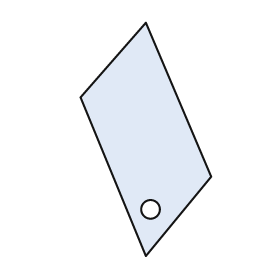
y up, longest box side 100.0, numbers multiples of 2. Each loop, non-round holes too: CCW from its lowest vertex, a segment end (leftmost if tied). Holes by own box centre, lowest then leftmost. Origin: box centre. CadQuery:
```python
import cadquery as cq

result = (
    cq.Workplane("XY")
    .moveTo(0.0, -50.0)
    .lineTo(28.0, -16.0)
    .lineTo(0.0, 50.0)
    .lineTo(-28.0, 18.0)
    .close()
    .moveTo(2.0, -30.0)
    .circle(4.0)
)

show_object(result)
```